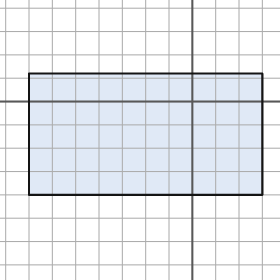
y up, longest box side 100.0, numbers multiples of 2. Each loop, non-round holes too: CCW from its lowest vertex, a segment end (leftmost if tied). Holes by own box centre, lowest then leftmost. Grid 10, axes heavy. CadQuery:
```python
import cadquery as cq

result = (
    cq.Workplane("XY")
    .moveTo(-70.0, -40.0)
    .lineTo(30.0, -40.0)
    .lineTo(30.0, 12.0)
    .lineTo(-70.0, 12.0)
    .close()
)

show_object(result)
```